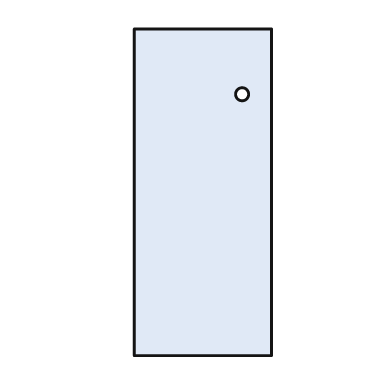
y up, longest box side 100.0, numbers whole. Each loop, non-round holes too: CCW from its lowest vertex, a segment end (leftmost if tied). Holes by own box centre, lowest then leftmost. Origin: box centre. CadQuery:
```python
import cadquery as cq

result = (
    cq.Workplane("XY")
    .moveTo(-21.0, -50.0)
    .lineTo(21.0, -50.0)
    .lineTo(21.0, 50.0)
    .lineTo(-21.0, 50.0)
    .close()
    .moveTo(12.0, 30.0)
    .circle(2.0)
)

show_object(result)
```